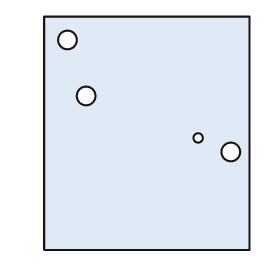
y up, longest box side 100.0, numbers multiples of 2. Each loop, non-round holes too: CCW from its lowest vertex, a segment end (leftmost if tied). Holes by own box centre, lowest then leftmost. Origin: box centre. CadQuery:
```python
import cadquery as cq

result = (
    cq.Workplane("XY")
    .moveTo(-44.0, -50.0)
    .lineTo(44.0, -50.0)
    .lineTo(44.0, 50.0)
    .lineTo(-44.0, 50.0)
    .close()
    .moveTo(36.0, -8.0)
    .circle(4.0)
    .moveTo(22.0, -2.0)
    .circle(2.0)
    .moveTo(-26.0, 16.0)
    .circle(4.0)
    .moveTo(-34.0, 40.0)
    .circle(4.0)
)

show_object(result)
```